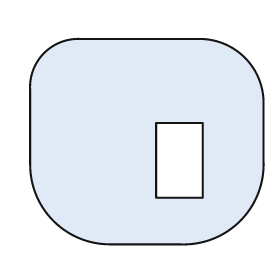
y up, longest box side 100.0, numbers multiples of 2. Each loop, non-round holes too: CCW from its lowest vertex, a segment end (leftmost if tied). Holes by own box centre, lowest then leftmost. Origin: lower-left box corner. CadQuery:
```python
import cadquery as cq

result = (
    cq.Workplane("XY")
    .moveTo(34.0, 0.0)
    .lineTo(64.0, 0.0)
    .threePointArc((90.0, 10.0), (100.0, 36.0))
    .lineTo(100.0, 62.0)
    .threePointArc((92.0, 80.0), (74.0, 88.0))
    .lineTo(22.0, 88.0)
    .threePointArc((6.0, 82.0), (0.0, 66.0))
    .lineTo(0.0, 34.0)
    .threePointArc((10.0, 10.0), (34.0, 0.0))
    .close()
    .moveTo(54.0, 20.0)
    .lineTo(74.0, 20.0)
    .lineTo(74.0, 52.0)
    .lineTo(54.0, 52.0)
    .close()
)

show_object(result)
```